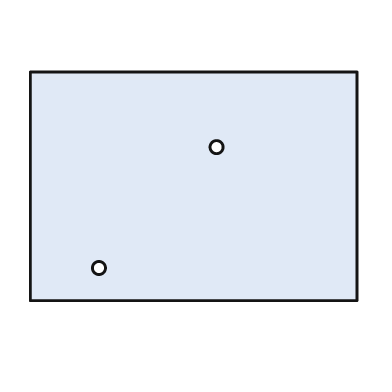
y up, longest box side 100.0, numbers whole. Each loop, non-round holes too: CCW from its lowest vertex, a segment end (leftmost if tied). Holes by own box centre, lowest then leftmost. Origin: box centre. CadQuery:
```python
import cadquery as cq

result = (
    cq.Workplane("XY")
    .moveTo(-50.0, -35.0)
    .lineTo(50.0, -35.0)
    .lineTo(50.0, 35.0)
    .lineTo(-50.0, 35.0)
    .close()
    .moveTo(-29.0, -25.0)
    .circle(2.0)
    .moveTo(7.0, 12.0)
    .circle(2.0)
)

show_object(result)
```